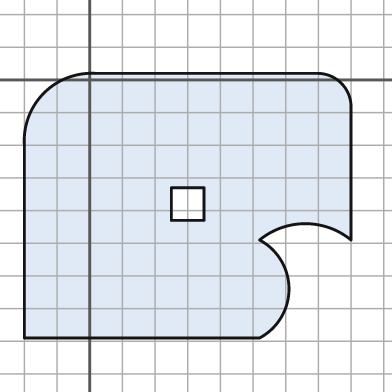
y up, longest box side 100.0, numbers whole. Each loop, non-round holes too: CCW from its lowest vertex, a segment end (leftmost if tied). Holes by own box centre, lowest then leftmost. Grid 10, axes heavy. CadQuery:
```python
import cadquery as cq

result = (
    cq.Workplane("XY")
    .moveTo(-20.0, -79.0)
    .lineTo(52.0, -79.0)
    .threePointArc((61.0, -64.0), (52.0, -49.0))
    .threePointArc((66.0, -44.0), (80.0, -49.0))
    .lineTo(80.0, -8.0)
    .threePointArc((77.0, -1.0), (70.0, 2.0))
    .lineTo(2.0, 2.0)
    .threePointArc((-14.0, -4.0), (-20.0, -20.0))
    .close()
    .moveTo(25.0, -43.0)
    .lineTo(35.0, -43.0)
    .lineTo(35.0, -33.0)
    .lineTo(25.0, -33.0)
    .close()
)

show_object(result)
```